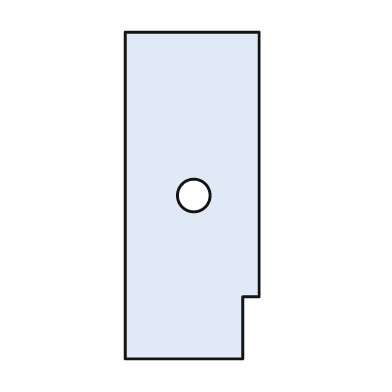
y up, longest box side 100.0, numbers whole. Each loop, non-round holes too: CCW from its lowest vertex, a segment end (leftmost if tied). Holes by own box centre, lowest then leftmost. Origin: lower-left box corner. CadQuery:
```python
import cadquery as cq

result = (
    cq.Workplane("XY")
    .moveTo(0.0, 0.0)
    .lineTo(36.0, 0.0)
    .lineTo(36.0, 19.0)
    .lineTo(41.0, 19.0)
    .lineTo(41.0, 100.0)
    .lineTo(0.0, 100.0)
    .close()
    .moveTo(21.0, 50.0)
    .circle(5.0)
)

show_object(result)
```